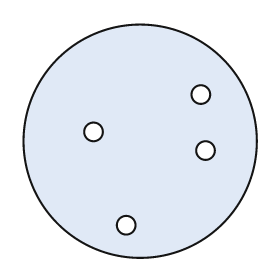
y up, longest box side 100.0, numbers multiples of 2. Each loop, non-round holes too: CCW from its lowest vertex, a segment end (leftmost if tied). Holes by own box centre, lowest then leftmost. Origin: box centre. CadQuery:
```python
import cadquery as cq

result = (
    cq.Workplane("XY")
    .moveTo(0.0, 0.0)
    .circle(50.0)
    .moveTo(-6.0, -36.0)
    .circle(4.0)
    .moveTo(28.0, -4.0)
    .circle(4.0)
    .moveTo(-20.0, 4.0)
    .circle(4.0)
    .moveTo(26.0, 20.0)
    .circle(4.0)
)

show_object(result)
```